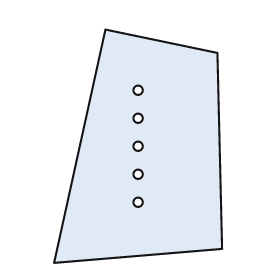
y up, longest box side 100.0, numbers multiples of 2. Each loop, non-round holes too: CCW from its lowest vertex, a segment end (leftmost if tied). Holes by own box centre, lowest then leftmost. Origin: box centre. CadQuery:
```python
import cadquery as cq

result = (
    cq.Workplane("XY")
    .moveTo(-36.0, -50.0)
    .lineTo(36.0, -44.0)
    .lineTo(34.0, 40.0)
    .lineTo(-14.0, 50.0)
    .close()
    .moveTo(0.0, -24.0)
    .circle(2.0)
    .moveTo(0.0, -12.0)
    .circle(2.0)
    .moveTo(0.0, 0.0)
    .circle(2.0)
    .moveTo(0.0, 12.0)
    .circle(2.0)
    .moveTo(0.0, 24.0)
    .circle(2.0)
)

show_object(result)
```